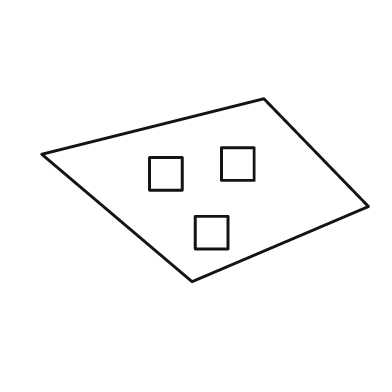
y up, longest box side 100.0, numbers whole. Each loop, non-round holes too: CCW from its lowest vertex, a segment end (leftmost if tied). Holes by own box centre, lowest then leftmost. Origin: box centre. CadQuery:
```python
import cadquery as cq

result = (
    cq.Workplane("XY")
    .moveTo(-4.0, -28.0)
    .lineTo(50.0, -5.0)
    .lineTo(18.0, 28.0)
    .lineTo(-50.0, 11.0)
    .close()
    .moveTo(-3.0, -18.0)
    .lineTo(7.0, -18.0)
    .lineTo(7.0, -8.0)
    .lineTo(-3.0, -8.0)
    .close()
    .moveTo(-17.0, 0.0)
    .lineTo(-7.0, 0.0)
    .lineTo(-7.0, 10.0)
    .lineTo(-17.0, 10.0)
    .close()
    .moveTo(5.0, 3.0)
    .lineTo(15.0, 3.0)
    .lineTo(15.0, 13.0)
    .lineTo(5.0, 13.0)
    .close()
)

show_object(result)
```